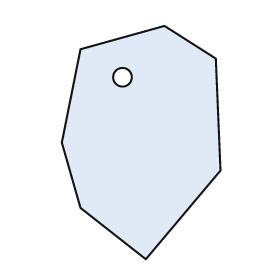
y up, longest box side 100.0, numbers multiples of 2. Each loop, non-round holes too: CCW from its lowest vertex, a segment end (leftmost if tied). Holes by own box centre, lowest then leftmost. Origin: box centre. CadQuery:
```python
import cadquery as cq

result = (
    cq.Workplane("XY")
    .moveTo(2.0, -50.0)
    .lineTo(34.0, -12.0)
    .lineTo(32.0, 36.0)
    .lineTo(10.0, 50.0)
    .lineTo(-26.0, 40.0)
    .lineTo(-34.0, 0.0)
    .lineTo(-26.0, -28.0)
    .close()
    .moveTo(-8.0, 28.0)
    .circle(4.0)
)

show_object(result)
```